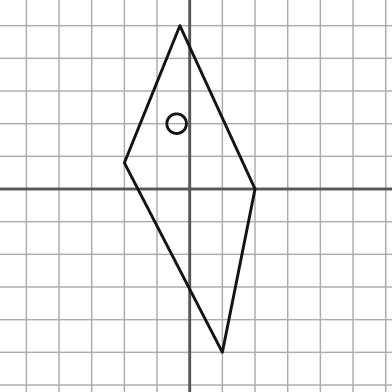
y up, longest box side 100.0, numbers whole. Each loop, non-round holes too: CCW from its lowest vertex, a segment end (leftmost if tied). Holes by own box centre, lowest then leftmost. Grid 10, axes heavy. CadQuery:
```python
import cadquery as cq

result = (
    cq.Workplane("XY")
    .moveTo(10.0, -50.0)
    .lineTo(20.0, 0.0)
    .lineTo(-3.0, 50.0)
    .lineTo(-20.0, 8.0)
    .close()
    .moveTo(-4.0, 20.0)
    .circle(3.0)
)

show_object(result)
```